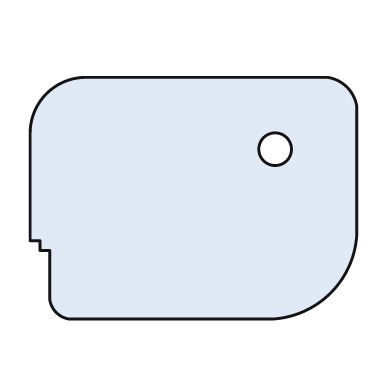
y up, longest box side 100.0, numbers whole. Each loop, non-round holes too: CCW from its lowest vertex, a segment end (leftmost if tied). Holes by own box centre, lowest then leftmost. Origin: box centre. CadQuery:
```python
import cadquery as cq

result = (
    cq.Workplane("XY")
    .moveTo(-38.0, -37.0)
    .lineTo(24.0, -37.0)
    .threePointArc((42.0, -29.0), (50.0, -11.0))
    .lineTo(50.0, 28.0)
    .threePointArc((47.0, 34.0), (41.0, 37.0))
    .lineTo(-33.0, 37.0)
    .threePointArc((-45.0, 32.0), (-50.0, 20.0))
    .lineTo(-50.0, -13.0)
    .lineTo(-47.0, -13.0)
    .lineTo(-47.0, -16.0)
    .lineTo(-44.0, -16.0)
    .lineTo(-44.0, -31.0)
    .threePointArc((-42.0, -35.0), (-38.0, -37.0))
    .close()
    .moveTo(25.0, 15.0)
    .circle(5.0)
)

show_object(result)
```